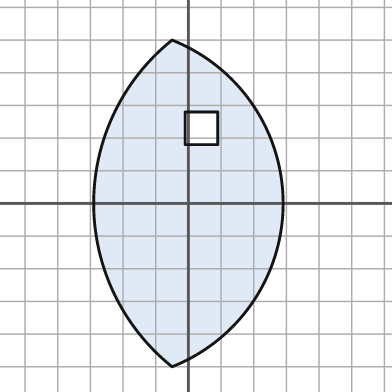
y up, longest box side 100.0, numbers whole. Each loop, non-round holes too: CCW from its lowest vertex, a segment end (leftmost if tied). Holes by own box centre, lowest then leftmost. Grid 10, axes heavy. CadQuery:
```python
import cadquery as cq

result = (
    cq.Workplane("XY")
    .moveTo(-5.0, -50.0)
    .threePointArc((29.0, 0.0), (-5.0, 50.0))
    .threePointArc((-29.0, 0.0), (-5.0, -50.0))
    .close()
    .moveTo(-1.0, 18.0)
    .lineTo(9.0, 18.0)
    .lineTo(9.0, 28.0)
    .lineTo(-1.0, 28.0)
    .close()
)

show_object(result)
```